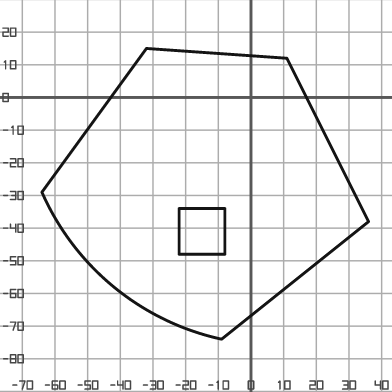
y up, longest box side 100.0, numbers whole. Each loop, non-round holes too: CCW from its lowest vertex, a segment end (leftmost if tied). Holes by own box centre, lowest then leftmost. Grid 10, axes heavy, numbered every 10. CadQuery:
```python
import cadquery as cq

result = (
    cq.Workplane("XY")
    .moveTo(-9.0, -74.0)
    .lineTo(36.0, -38.0)
    .lineTo(11.0, 12.0)
    .lineTo(-32.0, 15.0)
    .lineTo(-64.0, -29.0)
    .threePointArc((-42.0, -58.0), (-9.0, -74.0))
    .close()
    .moveTo(-22.0, -48.0)
    .lineTo(-8.0, -48.0)
    .lineTo(-8.0, -34.0)
    .lineTo(-22.0, -34.0)
    .close()
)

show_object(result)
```